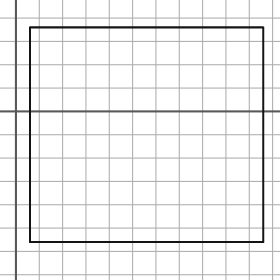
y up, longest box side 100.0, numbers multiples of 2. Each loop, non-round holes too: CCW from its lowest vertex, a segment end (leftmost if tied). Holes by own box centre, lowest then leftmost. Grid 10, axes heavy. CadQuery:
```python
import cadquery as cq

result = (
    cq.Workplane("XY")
    .moveTo(6.0, -56.0)
    .lineTo(106.0, -56.0)
    .lineTo(106.0, 36.0)
    .lineTo(6.0, 36.0)
    .close()
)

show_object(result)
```